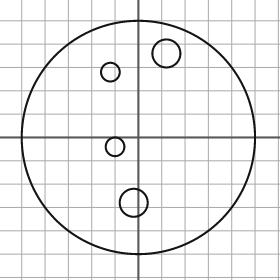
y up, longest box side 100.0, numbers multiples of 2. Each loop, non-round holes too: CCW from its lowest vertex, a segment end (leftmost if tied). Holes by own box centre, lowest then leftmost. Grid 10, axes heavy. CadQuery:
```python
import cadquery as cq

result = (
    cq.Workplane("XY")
    .moveTo(0.0, 0.0)
    .circle(50.0)
    .moveTo(-2.0, -28.0)
    .circle(6.0)
    .moveTo(-10.0, -4.0)
    .circle(4.0)
    .moveTo(-12.0, 28.0)
    .circle(4.0)
    .moveTo(12.0, 36.0)
    .circle(6.0)
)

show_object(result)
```